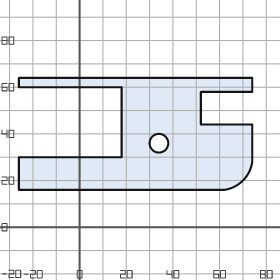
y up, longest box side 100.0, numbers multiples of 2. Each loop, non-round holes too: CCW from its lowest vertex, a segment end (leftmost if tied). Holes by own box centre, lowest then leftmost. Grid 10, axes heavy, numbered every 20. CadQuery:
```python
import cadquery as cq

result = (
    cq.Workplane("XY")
    .moveTo(-26.0, 16.0)
    .lineTo(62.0, 16.0)
    .threePointArc((70.0, 20.0), (74.0, 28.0))
    .lineTo(74.0, 44.0)
    .lineTo(52.0, 44.0)
    .lineTo(52.0, 58.0)
    .lineTo(74.0, 58.0)
    .lineTo(74.0, 64.0)
    .lineTo(-26.0, 64.0)
    .lineTo(-26.0, 60.0)
    .lineTo(18.0, 60.0)
    .lineTo(18.0, 30.0)
    .lineTo(-26.0, 30.0)
    .close()
    .moveTo(34.0, 36.0)
    .circle(4.0)
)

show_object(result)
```